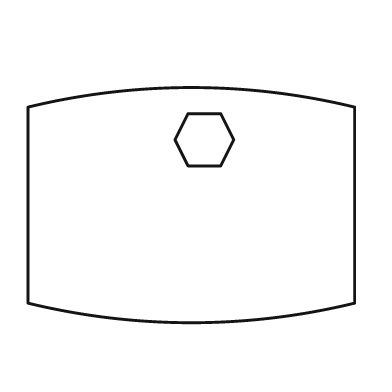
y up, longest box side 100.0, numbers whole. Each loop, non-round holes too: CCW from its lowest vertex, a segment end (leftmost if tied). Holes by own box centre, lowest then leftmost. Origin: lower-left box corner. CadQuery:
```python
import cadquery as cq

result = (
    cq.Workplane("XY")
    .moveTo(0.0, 6.0)
    .threePointArc((50.0, 0.0), (100.0, 6.0))
    .lineTo(100.0, 66.0)
    .threePointArc((50.0, 72.0), (0.0, 66.0))
    .close()
    .moveTo(49.0, 48.0)
    .lineTo(59.0, 48.0)
    .lineTo(63.0, 56.0)
    .lineTo(59.0, 64.0)
    .lineTo(49.0, 64.0)
    .lineTo(45.0, 56.0)
    .close()
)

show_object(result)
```